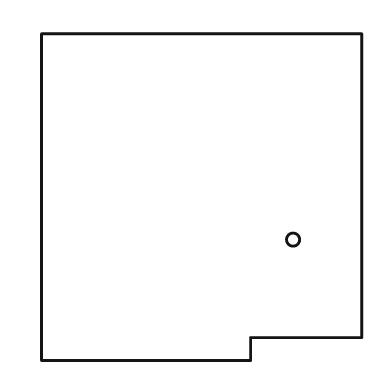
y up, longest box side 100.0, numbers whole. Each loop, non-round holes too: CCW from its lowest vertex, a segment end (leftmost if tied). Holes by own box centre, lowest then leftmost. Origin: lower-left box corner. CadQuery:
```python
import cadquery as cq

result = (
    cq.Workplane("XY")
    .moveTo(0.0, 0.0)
    .lineTo(64.0, 0.0)
    .lineTo(64.0, 7.0)
    .lineTo(98.0, 7.0)
    .lineTo(98.0, 100.0)
    .lineTo(0.0, 100.0)
    .close()
    .moveTo(77.0, 37.0)
    .circle(2.0)
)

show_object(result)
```